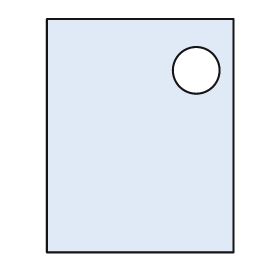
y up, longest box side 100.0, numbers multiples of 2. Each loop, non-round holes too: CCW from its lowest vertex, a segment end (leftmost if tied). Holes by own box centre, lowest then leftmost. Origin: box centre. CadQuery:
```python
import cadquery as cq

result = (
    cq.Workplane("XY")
    .moveTo(-40.0, -50.0)
    .lineTo(40.0, -50.0)
    .lineTo(40.0, 50.0)
    .lineTo(-40.0, 50.0)
    .close()
    .moveTo(24.0, 28.0)
    .circle(10.0)
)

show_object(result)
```